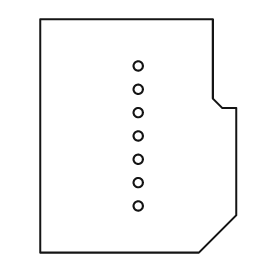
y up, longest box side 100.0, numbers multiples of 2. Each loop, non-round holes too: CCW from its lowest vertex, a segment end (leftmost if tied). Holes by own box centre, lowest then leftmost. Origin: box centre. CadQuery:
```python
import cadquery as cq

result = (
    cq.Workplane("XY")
    .moveTo(-42.0, -50.0)
    .lineTo(26.0, -50.0)
    .lineTo(42.0, -34.0)
    .lineTo(42.0, 12.0)
    .lineTo(36.0, 12.0)
    .lineTo(32.0, 16.0)
    .lineTo(32.0, 50.0)
    .lineTo(-42.0, 50.0)
    .close()
    .moveTo(0.0, -30.0)
    .circle(2.0)
    .moveTo(0.0, -20.0)
    .circle(2.0)
    .moveTo(0.0, -10.0)
    .circle(2.0)
    .moveTo(0.0, 0.0)
    .circle(2.0)
    .moveTo(0.0, 10.0)
    .circle(2.0)
    .moveTo(0.0, 20.0)
    .circle(2.0)
    .moveTo(0.0, 30.0)
    .circle(2.0)
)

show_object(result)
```